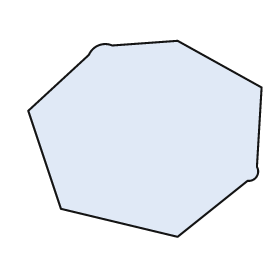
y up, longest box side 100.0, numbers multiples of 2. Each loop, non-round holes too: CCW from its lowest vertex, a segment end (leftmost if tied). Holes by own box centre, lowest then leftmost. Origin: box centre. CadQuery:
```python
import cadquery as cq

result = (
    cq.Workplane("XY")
    .moveTo(14.0, -42.0)
    .lineTo(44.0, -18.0)
    .threePointArc((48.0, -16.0), (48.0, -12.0))
    .lineTo(50.0, 22.0)
    .lineTo(14.0, 42.0)
    .lineTo(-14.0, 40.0)
    .threePointArc((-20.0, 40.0), (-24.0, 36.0))
    .lineTo(-50.0, 12.0)
    .lineTo(-36.0, -30.0)
    .close()
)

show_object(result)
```